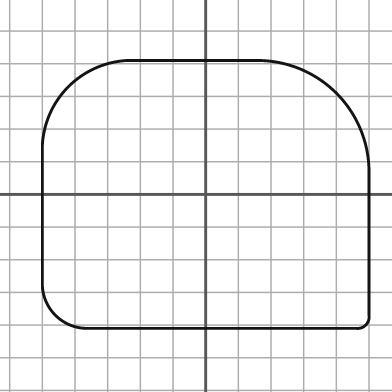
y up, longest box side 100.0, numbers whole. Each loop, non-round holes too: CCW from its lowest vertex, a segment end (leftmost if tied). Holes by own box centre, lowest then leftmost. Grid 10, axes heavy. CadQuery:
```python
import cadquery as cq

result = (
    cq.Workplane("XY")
    .moveTo(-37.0, -41.0)
    .lineTo(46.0, -41.0)
    .threePointArc((49.0, -40.0), (50.0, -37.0))
    .lineTo(50.0, 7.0)
    .threePointArc((40.0, 31.0), (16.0, 41.0))
    .lineTo(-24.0, 41.0)
    .threePointArc((-42.0, 33.0), (-50.0, 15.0))
    .lineTo(-50.0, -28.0)
    .threePointArc((-46.0, -37.0), (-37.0, -41.0))
    .close()
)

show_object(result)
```